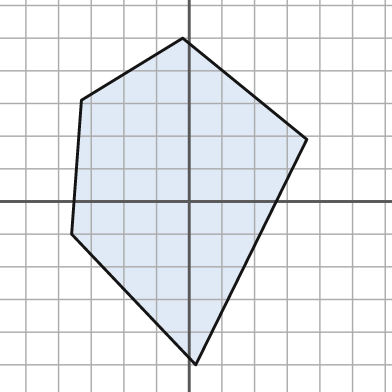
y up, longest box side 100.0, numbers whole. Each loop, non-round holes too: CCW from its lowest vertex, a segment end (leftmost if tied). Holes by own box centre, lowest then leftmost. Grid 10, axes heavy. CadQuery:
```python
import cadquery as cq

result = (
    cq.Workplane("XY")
    .moveTo(2.0, -50.0)
    .lineTo(36.0, 19.0)
    .lineTo(-2.0, 50.0)
    .lineTo(-33.0, 31.0)
    .lineTo(-36.0, -10.0)
    .close()
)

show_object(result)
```